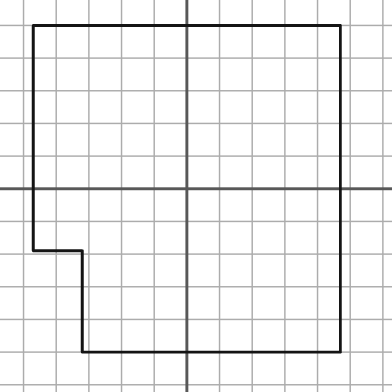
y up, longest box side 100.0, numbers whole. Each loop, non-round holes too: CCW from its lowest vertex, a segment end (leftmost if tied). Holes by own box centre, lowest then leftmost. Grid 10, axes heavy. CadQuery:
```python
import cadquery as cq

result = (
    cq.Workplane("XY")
    .moveTo(-32.0, -50.0)
    .lineTo(47.0, -50.0)
    .lineTo(47.0, 50.0)
    .lineTo(-47.0, 50.0)
    .lineTo(-47.0, -19.0)
    .lineTo(-32.0, -19.0)
    .close()
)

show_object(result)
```